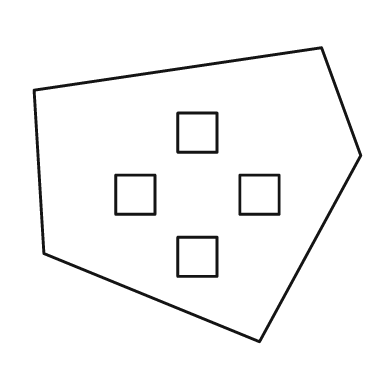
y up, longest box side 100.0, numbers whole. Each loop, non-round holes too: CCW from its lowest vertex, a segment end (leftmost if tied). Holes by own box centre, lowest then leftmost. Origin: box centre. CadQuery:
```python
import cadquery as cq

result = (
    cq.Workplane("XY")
    .moveTo(19.0, -45.0)
    .lineTo(50.0, 12.0)
    .lineTo(38.0, 45.0)
    .lineTo(-50.0, 32.0)
    .lineTo(-47.0, -18.0)
    .close()
    .moveTo(-6.0, -25.0)
    .lineTo(6.0, -25.0)
    .lineTo(6.0, -13.0)
    .lineTo(-6.0, -13.0)
    .close()
    .moveTo(-25.0, -6.0)
    .lineTo(-13.0, -6.0)
    .lineTo(-13.0, 6.0)
    .lineTo(-25.0, 6.0)
    .close()
    .moveTo(13.0, -6.0)
    .lineTo(25.0, -6.0)
    .lineTo(25.0, 6.0)
    .lineTo(13.0, 6.0)
    .close()
    .moveTo(-6.0, 13.0)
    .lineTo(6.0, 13.0)
    .lineTo(6.0, 25.0)
    .lineTo(-6.0, 25.0)
    .close()
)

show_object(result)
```